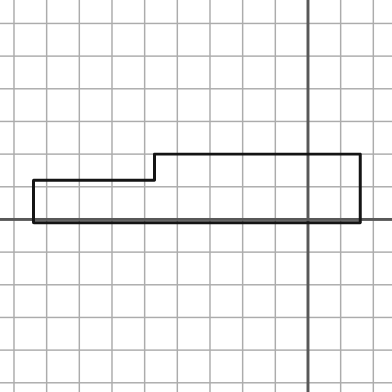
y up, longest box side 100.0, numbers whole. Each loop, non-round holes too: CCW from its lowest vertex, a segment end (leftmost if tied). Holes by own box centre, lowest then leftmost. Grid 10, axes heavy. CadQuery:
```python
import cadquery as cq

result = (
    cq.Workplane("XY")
    .moveTo(-84.0, -1.0)
    .lineTo(16.0, -1.0)
    .lineTo(16.0, 20.0)
    .lineTo(-47.0, 20.0)
    .lineTo(-47.0, 12.0)
    .lineTo(-84.0, 12.0)
    .close()
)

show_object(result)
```